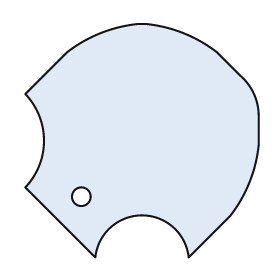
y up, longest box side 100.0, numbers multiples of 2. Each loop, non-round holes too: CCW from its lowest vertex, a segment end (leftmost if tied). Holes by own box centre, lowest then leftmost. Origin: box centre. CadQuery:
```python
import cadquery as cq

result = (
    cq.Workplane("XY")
    .moveTo(-20.0, -50.0)
    .threePointArc((0.0, -32.0), (20.0, -50.0))
    .lineTo(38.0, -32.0)
    .threePointArc((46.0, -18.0), (50.0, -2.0))
    .lineTo(50.0, 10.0)
    .threePointArc((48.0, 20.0), (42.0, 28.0))
    .lineTo(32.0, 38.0)
    .threePointArc((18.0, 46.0), (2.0, 50.0))
    .lineTo(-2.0, 50.0)
    .threePointArc((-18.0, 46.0), (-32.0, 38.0))
    .lineTo(-50.0, 20.0)
    .threePointArc((-42.0, 0.0), (-50.0, -20.0))
    .close()
    .moveTo(-26.0, -24.0)
    .circle(4.0)
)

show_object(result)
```